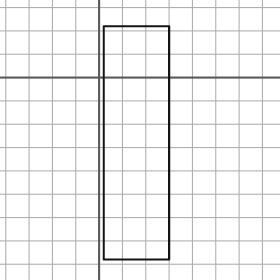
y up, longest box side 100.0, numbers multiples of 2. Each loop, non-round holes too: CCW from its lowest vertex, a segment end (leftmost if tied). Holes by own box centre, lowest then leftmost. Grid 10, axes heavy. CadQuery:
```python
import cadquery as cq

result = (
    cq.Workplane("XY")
    .moveTo(2.0, -78.0)
    .lineTo(30.0, -78.0)
    .lineTo(30.0, 22.0)
    .lineTo(2.0, 22.0)
    .close()
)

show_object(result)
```